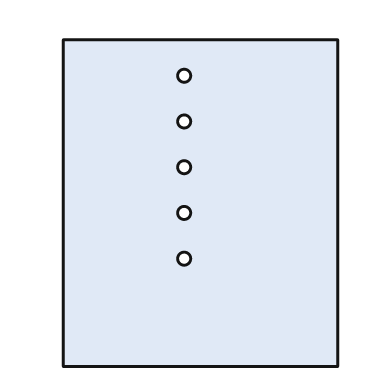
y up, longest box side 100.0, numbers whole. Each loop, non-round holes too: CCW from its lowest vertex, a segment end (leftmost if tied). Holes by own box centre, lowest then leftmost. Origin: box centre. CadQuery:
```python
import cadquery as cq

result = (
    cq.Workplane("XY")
    .moveTo(-42.0, -50.0)
    .lineTo(42.0, -50.0)
    .lineTo(42.0, 50.0)
    .lineTo(-42.0, 50.0)
    .close()
    .moveTo(-5.0, -17.0)
    .circle(2.0)
    .moveTo(-5.0, -3.0)
    .circle(2.0)
    .moveTo(-5.0, 11.0)
    .circle(2.0)
    .moveTo(-5.0, 25.0)
    .circle(2.0)
    .moveTo(-5.0, 39.0)
    .circle(2.0)
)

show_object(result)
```